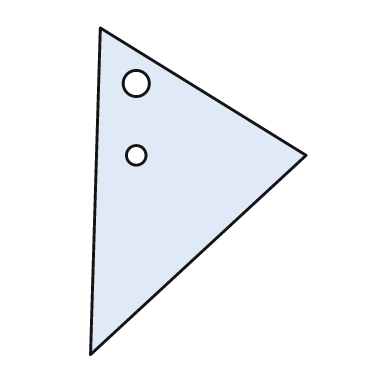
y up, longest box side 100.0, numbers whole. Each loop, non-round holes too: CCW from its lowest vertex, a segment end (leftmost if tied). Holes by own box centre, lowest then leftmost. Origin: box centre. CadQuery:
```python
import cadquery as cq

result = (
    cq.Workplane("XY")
    .moveTo(-33.0, -50.0)
    .lineTo(33.0, 11.0)
    .lineTo(-30.0, 50.0)
    .close()
    .moveTo(-19.0, 11.0)
    .circle(3.0)
    .moveTo(-19.0, 33.0)
    .circle(4.0)
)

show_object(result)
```